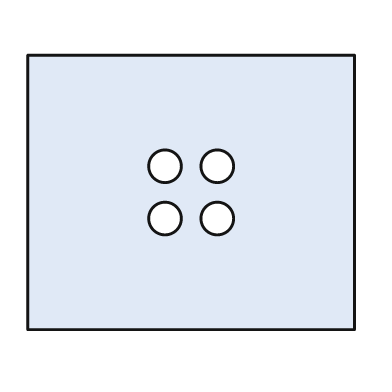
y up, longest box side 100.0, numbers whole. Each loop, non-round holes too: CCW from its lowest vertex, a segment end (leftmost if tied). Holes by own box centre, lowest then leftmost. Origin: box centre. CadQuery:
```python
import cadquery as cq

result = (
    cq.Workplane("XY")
    .moveTo(-50.0, -42.0)
    .lineTo(50.0, -42.0)
    .lineTo(50.0, 42.0)
    .lineTo(-50.0, 42.0)
    .close()
    .moveTo(-8.0, -8.0)
    .circle(5.0)
    .moveTo(8.0, -8.0)
    .circle(5.0)
    .moveTo(-8.0, 8.0)
    .circle(5.0)
    .moveTo(8.0, 8.0)
    .circle(5.0)
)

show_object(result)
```